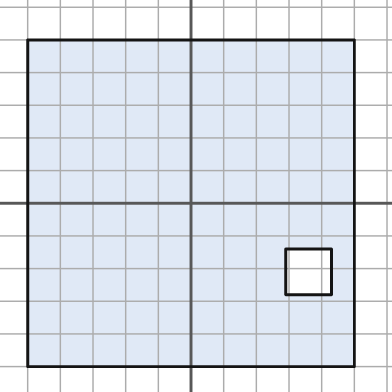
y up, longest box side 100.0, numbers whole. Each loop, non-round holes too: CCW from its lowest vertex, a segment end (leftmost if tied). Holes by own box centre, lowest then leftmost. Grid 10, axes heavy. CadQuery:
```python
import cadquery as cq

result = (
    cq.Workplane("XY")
    .moveTo(-50.0, -50.0)
    .lineTo(50.0, -50.0)
    .lineTo(50.0, 50.0)
    .lineTo(-50.0, 50.0)
    .close()
    .moveTo(29.0, -28.0)
    .lineTo(43.0, -28.0)
    .lineTo(43.0, -14.0)
    .lineTo(29.0, -14.0)
    .close()
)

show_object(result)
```